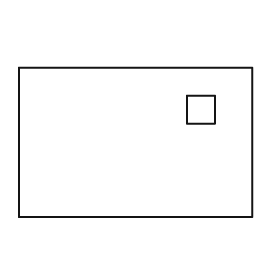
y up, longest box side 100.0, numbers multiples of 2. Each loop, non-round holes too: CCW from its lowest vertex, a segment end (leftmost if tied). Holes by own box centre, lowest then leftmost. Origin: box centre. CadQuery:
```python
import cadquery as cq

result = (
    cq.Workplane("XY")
    .moveTo(-50.0, -32.0)
    .lineTo(50.0, -32.0)
    .lineTo(50.0, 32.0)
    .lineTo(-50.0, 32.0)
    .close()
    .moveTo(22.0, 8.0)
    .lineTo(34.0, 8.0)
    .lineTo(34.0, 20.0)
    .lineTo(22.0, 20.0)
    .close()
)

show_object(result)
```